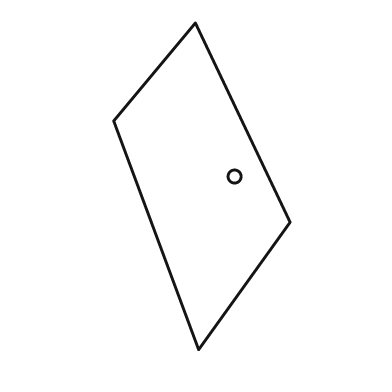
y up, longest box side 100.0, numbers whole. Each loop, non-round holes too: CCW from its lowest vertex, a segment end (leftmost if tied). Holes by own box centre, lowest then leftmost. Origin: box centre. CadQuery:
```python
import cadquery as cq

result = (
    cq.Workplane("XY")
    .moveTo(-1.0, -50.0)
    .lineTo(27.0, -11.0)
    .lineTo(-2.0, 50.0)
    .lineTo(-27.0, 20.0)
    .close()
    .moveTo(10.0, 3.0)
    .circle(2.0)
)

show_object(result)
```